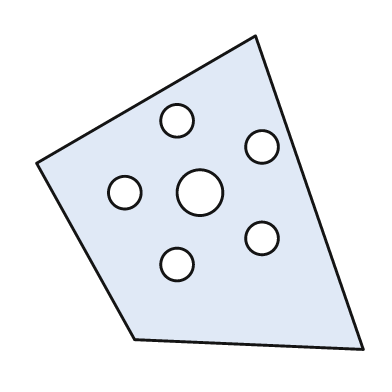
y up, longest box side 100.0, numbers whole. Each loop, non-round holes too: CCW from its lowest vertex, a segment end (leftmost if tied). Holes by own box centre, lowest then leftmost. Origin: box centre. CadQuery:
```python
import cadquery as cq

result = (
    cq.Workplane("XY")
    .moveTo(50.0, -48.0)
    .lineTo(17.0, 48.0)
    .lineTo(-50.0, 9.0)
    .lineTo(-20.0, -45.0)
    .close()
    .moveTo(-7.0, -22.0)
    .circle(5.0)
    .moveTo(19.0, -14.0)
    .circle(5.0)
    .moveTo(-23.0, 0.0)
    .circle(5.0)
    .moveTo(0.0, 0.0)
    .circle(7.0)
    .moveTo(19.0, 14.0)
    .circle(5.0)
    .moveTo(-7.0, 22.0)
    .circle(5.0)
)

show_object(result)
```